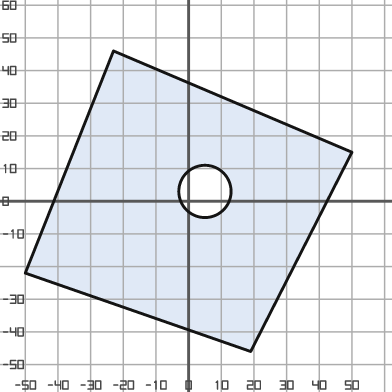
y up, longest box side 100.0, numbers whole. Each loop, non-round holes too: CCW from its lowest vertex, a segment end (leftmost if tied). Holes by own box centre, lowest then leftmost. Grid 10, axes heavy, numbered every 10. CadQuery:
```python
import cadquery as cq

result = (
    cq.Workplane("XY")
    .moveTo(19.0, -46.0)
    .lineTo(50.0, 15.0)
    .lineTo(-23.0, 46.0)
    .lineTo(-50.0, -22.0)
    .close()
    .moveTo(5.0, 3.0)
    .circle(8.0)
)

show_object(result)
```